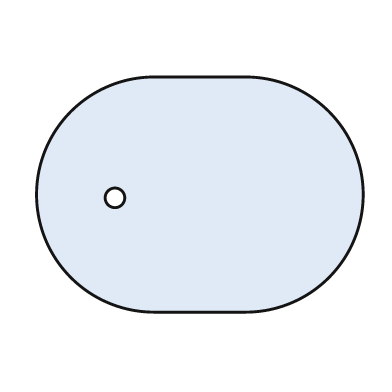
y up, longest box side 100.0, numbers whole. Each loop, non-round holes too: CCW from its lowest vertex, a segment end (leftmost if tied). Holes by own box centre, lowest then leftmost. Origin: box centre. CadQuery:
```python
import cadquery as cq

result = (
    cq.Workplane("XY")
    .moveTo(-14.0, -36.0)
    .lineTo(14.0, -36.0)
    .threePointArc((50.0, 0.0), (14.0, 36.0))
    .lineTo(-14.0, 36.0)
    .threePointArc((-50.0, 0.0), (-14.0, -36.0))
    .close()
    .moveTo(-26.0, -1.0)
    .circle(3.0)
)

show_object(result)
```